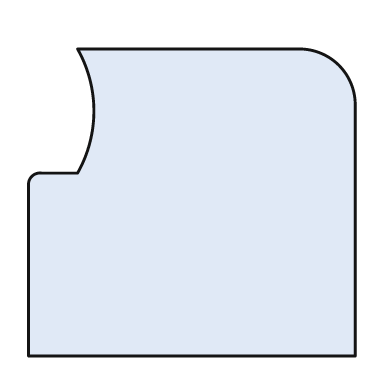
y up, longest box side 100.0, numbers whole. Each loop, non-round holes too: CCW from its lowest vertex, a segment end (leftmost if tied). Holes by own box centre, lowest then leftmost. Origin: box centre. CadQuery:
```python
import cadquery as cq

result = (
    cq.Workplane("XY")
    .moveTo(-50.0, -47.0)
    .lineTo(50.0, -47.0)
    .lineTo(50.0, 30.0)
    .threePointArc((45.0, 42.0), (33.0, 47.0))
    .lineTo(-35.0, 47.0)
    .threePointArc((-30.0, 28.0), (-35.0, 9.0))
    .lineTo(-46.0, 9.0)
    .threePointArc((-49.0, 8.0), (-50.0, 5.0))
    .close()
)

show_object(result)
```